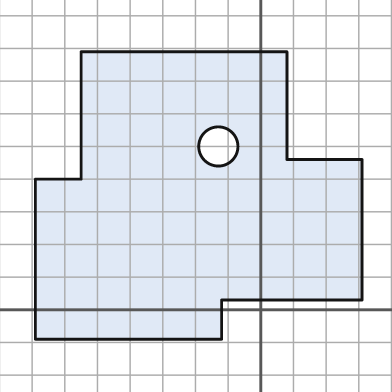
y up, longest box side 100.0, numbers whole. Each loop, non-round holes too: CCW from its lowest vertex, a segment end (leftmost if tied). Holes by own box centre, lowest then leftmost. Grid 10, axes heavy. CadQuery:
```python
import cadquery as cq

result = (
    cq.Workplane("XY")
    .moveTo(-69.0, -9.0)
    .lineTo(-12.0, -9.0)
    .lineTo(-12.0, 3.0)
    .lineTo(31.0, 3.0)
    .lineTo(31.0, 46.0)
    .lineTo(8.0, 46.0)
    .lineTo(8.0, 79.0)
    .lineTo(-55.0, 79.0)
    .lineTo(-55.0, 40.0)
    .lineTo(-69.0, 40.0)
    .close()
    .moveTo(-13.0, 50.0)
    .circle(6.0)
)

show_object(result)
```